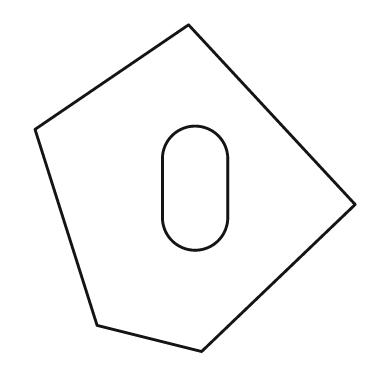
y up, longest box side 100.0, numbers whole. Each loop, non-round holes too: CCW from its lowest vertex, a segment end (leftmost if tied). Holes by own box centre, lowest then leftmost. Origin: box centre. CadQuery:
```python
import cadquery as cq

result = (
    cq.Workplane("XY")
    .moveTo(2.0, -50.0)
    .lineTo(49.0, -5.0)
    .lineTo(-2.0, 50.0)
    .lineTo(-49.0, 18.0)
    .lineTo(-30.0, -42.0)
    .close()
    .moveTo(-10.0, -9.0)
    .threePointArc((0.0, -19.0), (10.0, -9.0))
    .lineTo(10.0, 9.0)
    .threePointArc((0.0, 19.0), (-10.0, 9.0))
    .close()
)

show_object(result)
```